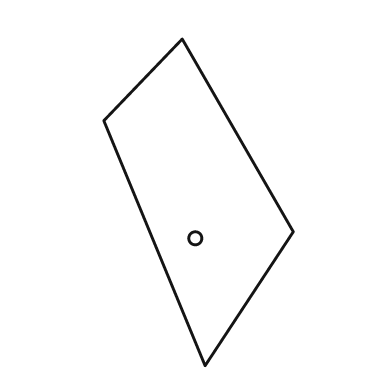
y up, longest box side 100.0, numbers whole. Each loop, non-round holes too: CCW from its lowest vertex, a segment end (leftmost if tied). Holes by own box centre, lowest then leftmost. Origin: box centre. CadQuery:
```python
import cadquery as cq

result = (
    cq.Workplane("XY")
    .moveTo(2.0, -50.0)
    .lineTo(29.0, -9.0)
    .lineTo(-5.0, 50.0)
    .lineTo(-29.0, 25.0)
    .close()
    .moveTo(-1.0, -11.0)
    .circle(2.0)
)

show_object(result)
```